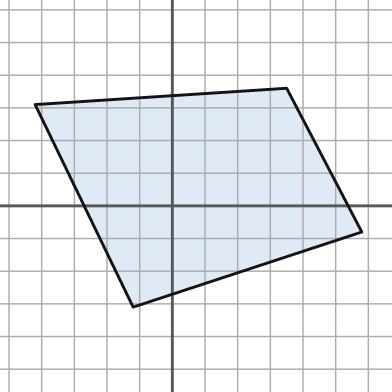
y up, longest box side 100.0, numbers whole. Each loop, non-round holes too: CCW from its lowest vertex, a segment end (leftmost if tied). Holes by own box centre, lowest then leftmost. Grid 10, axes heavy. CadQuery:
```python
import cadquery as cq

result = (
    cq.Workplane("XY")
    .moveTo(-12.0, -31.0)
    .lineTo(58.0, -8.0)
    .lineTo(35.0, 36.0)
    .lineTo(-42.0, 31.0)
    .close()
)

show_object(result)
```